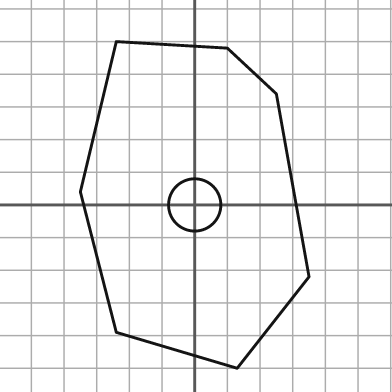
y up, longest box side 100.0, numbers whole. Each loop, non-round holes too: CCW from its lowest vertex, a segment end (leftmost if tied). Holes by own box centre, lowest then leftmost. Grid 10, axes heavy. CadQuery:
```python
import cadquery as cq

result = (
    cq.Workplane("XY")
    .moveTo(13.0, -50.0)
    .lineTo(35.0, -22.0)
    .lineTo(25.0, 34.0)
    .lineTo(10.0, 48.0)
    .lineTo(-24.0, 50.0)
    .lineTo(-35.0, 4.0)
    .lineTo(-24.0, -39.0)
    .close()
    .moveTo(0.0, 0.0)
    .circle(8.0)
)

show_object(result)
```